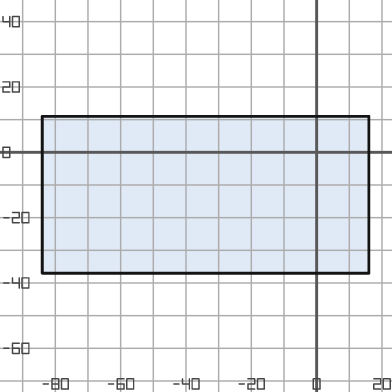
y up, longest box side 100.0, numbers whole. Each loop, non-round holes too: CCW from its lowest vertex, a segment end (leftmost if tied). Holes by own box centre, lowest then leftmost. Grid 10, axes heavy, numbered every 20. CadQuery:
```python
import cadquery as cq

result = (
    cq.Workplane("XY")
    .moveTo(-84.0, -37.0)
    .lineTo(16.0, -37.0)
    .lineTo(16.0, 11.0)
    .lineTo(-84.0, 11.0)
    .close()
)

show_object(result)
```